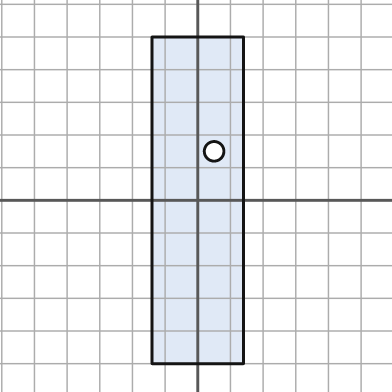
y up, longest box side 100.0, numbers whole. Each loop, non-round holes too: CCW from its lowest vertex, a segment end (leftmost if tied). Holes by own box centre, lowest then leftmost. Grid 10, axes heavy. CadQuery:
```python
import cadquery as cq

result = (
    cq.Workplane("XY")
    .moveTo(-14.0, -50.0)
    .lineTo(14.0, -50.0)
    .lineTo(14.0, 50.0)
    .lineTo(-14.0, 50.0)
    .close()
    .moveTo(5.0, 15.0)
    .circle(3.0)
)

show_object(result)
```